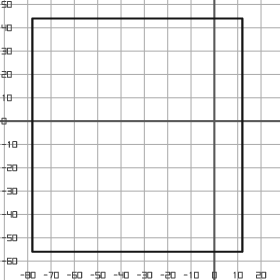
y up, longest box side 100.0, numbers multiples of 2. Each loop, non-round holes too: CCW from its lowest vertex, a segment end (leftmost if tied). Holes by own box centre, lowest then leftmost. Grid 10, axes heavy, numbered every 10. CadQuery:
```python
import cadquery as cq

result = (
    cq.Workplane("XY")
    .moveTo(-78.0, -56.0)
    .lineTo(12.0, -56.0)
    .lineTo(12.0, 44.0)
    .lineTo(-78.0, 44.0)
    .close()
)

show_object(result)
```